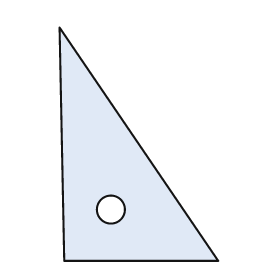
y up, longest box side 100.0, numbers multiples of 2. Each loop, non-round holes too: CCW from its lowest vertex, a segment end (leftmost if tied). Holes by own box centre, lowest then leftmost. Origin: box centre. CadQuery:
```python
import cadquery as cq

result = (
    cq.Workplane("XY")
    .moveTo(-32.0, -50.0)
    .lineTo(34.0, -50.0)
    .lineTo(-34.0, 50.0)
    .close()
    .moveTo(-12.0, -28.0)
    .circle(6.0)
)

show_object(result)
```